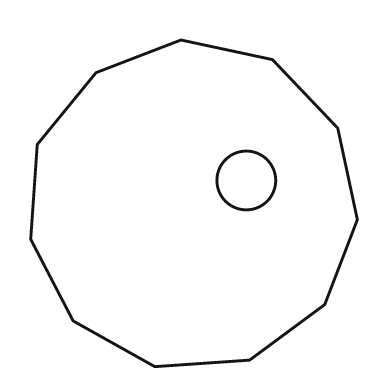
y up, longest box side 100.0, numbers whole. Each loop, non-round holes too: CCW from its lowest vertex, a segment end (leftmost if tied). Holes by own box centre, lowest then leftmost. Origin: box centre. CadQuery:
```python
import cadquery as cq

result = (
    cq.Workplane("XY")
    .moveTo(-12.0, -50.0)
    .lineTo(17.0, -48.0)
    .lineTo(40.0, -31.0)
    .lineTo(50.0, -5.0)
    .lineTo(44.0, 23.0)
    .lineTo(24.0, 44.0)
    .lineTo(-4.0, 50.0)
    .lineTo(-30.0, 40.0)
    .lineTo(-48.0, 18.0)
    .lineTo(-50.0, -11.0)
    .lineTo(-37.0, -36.0)
    .close()
    .moveTo(16.0, 7.0)
    .circle(9.0)
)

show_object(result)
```